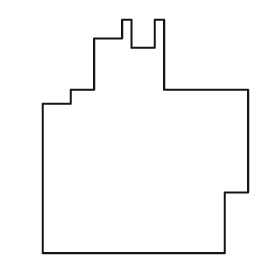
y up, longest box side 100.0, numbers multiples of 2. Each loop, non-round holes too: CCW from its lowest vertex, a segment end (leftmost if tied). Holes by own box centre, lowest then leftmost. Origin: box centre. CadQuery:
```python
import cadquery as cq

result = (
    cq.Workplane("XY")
    .moveTo(-44.0, -50.0)
    .lineTo(34.0, -50.0)
    .lineTo(34.0, -24.0)
    .lineTo(44.0, -24.0)
    .lineTo(44.0, 20.0)
    .lineTo(8.0, 20.0)
    .lineTo(8.0, 50.0)
    .lineTo(4.0, 50.0)
    .lineTo(4.0, 38.0)
    .lineTo(-6.0, 38.0)
    .lineTo(-6.0, 50.0)
    .lineTo(-10.0, 50.0)
    .lineTo(-10.0, 42.0)
    .lineTo(-22.0, 42.0)
    .lineTo(-22.0, 20.0)
    .lineTo(-32.0, 20.0)
    .lineTo(-32.0, 14.0)
    .lineTo(-44.0, 14.0)
    .close()
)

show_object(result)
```